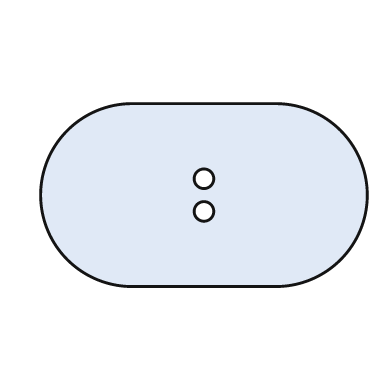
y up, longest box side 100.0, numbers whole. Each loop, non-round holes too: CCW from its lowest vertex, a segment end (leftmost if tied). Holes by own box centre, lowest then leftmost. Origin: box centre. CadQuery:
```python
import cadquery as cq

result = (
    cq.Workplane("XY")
    .moveTo(-22.0, -28.0)
    .lineTo(22.0, -28.0)
    .threePointArc((50.0, 0.0), (22.0, 28.0))
    .lineTo(-22.0, 28.0)
    .threePointArc((-50.0, 0.0), (-22.0, -28.0))
    .close()
    .moveTo(0.0, -5.0)
    .circle(3.0)
    .moveTo(0.0, 5.0)
    .circle(3.0)
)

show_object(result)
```